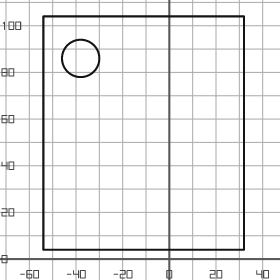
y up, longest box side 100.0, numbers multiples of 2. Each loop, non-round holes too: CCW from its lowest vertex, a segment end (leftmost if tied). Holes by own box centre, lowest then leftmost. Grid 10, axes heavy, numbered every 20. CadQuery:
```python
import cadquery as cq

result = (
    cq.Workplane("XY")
    .moveTo(-54.0, 4.0)
    .lineTo(32.0, 4.0)
    .lineTo(32.0, 104.0)
    .lineTo(-54.0, 104.0)
    .close()
    .moveTo(-38.0, 86.0)
    .circle(8.0)
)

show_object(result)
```